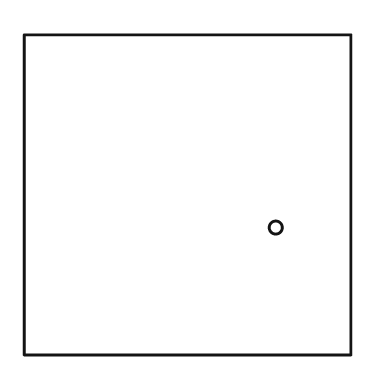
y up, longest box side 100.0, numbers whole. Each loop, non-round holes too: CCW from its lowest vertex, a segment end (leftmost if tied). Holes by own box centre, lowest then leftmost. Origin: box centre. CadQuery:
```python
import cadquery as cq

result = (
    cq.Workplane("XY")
    .moveTo(-50.0, -49.0)
    .lineTo(50.0, -49.0)
    .lineTo(50.0, 49.0)
    .lineTo(-50.0, 49.0)
    .close()
    .moveTo(27.0, -10.0)
    .circle(2.0)
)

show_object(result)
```